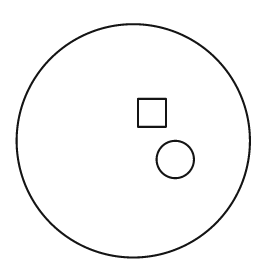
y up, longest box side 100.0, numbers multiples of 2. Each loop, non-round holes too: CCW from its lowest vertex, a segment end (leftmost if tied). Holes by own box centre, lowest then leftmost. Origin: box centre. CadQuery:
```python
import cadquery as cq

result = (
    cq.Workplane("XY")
    .moveTo(0.0, 0.0)
    .circle(50.0)
    .moveTo(18.0, -8.0)
    .circle(8.0)
    .moveTo(2.0, 6.0)
    .lineTo(14.0, 6.0)
    .lineTo(14.0, 18.0)
    .lineTo(2.0, 18.0)
    .close()
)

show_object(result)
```